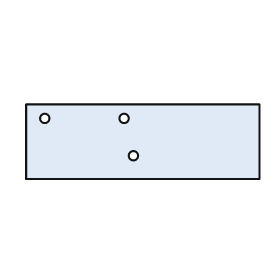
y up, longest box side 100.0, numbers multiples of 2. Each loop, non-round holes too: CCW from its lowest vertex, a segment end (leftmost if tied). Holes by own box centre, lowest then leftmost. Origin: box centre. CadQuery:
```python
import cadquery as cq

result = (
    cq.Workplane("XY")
    .moveTo(-50.0, -16.0)
    .lineTo(50.0, -16.0)
    .lineTo(50.0, 16.0)
    .lineTo(-50.0, 16.0)
    .close()
    .moveTo(-4.0, -6.0)
    .circle(2.0)
    .moveTo(-42.0, 10.0)
    .circle(2.0)
    .moveTo(-8.0, 10.0)
    .circle(2.0)
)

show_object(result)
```